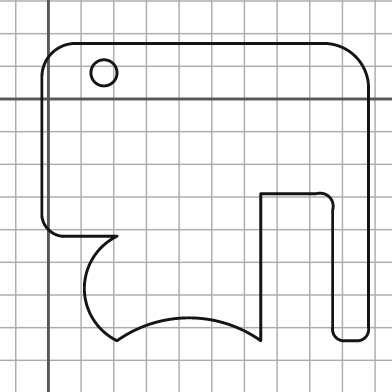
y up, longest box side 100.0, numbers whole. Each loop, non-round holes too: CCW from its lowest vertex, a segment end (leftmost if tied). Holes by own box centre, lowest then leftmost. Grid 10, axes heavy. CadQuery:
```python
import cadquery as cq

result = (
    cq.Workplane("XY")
    .moveTo(21.0, -74.0)
    .threePointArc((43.0, -67.0), (65.0, -74.0))
    .lineTo(65.0, -29.0)
    .lineTo(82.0, -29.0)
    .threePointArc((86.0, -30.0), (87.0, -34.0))
    .lineTo(87.0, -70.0)
    .threePointArc((88.0, -73.0), (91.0, -74.0))
    .lineTo(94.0, -74.0)
    .threePointArc((97.0, -73.0), (98.0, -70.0))
    .lineTo(98.0, 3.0)
    .threePointArc((94.0, 13.0), (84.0, 17.0))
    .lineTo(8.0, 17.0)
    .threePointArc((1.0, 14.0), (-2.0, 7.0))
    .lineTo(-2.0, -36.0)
    .threePointArc((0.0, -40.0), (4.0, -42.0))
    .lineTo(21.0, -42.0)
    .threePointArc((11.0, -58.0), (21.0, -74.0))
    .close()
    .moveTo(17.0, 8.0)
    .circle(4.0)
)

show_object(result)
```